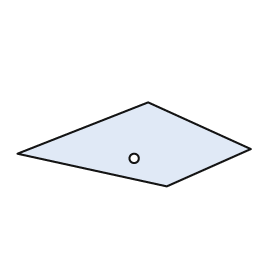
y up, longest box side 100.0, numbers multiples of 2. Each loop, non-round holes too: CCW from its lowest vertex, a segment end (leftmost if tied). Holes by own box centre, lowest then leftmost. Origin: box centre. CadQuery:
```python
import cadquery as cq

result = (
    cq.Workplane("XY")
    .moveTo(14.0, -18.0)
    .lineTo(50.0, -2.0)
    .lineTo(6.0, 18.0)
    .lineTo(-50.0, -4.0)
    .close()
    .moveTo(0.0, -6.0)
    .circle(2.0)
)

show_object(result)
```